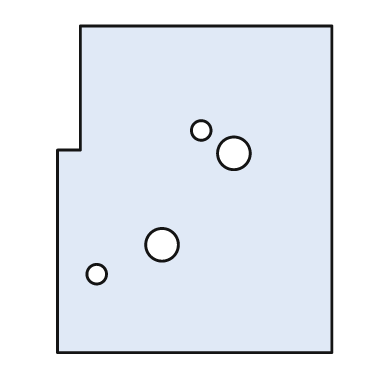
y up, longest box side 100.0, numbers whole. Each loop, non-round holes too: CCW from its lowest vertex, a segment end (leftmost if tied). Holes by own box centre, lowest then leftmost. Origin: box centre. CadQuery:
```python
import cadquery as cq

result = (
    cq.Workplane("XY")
    .moveTo(-42.0, -50.0)
    .lineTo(42.0, -50.0)
    .lineTo(42.0, 50.0)
    .lineTo(-35.0, 50.0)
    .lineTo(-35.0, 12.0)
    .lineTo(-42.0, 12.0)
    .close()
    .moveTo(-30.0, -26.0)
    .circle(3.0)
    .moveTo(-10.0, -17.0)
    .circle(5.0)
    .moveTo(12.0, 11.0)
    .circle(5.0)
    .moveTo(2.0, 18.0)
    .circle(3.0)
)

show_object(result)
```